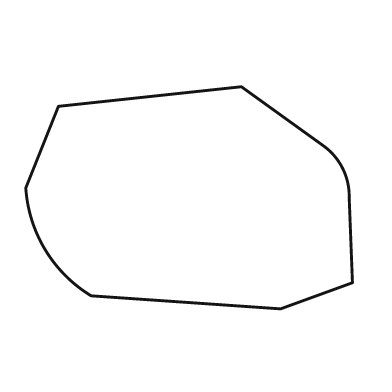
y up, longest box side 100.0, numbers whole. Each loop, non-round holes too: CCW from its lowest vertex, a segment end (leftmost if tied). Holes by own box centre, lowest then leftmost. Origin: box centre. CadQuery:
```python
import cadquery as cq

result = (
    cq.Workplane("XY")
    .moveTo(28.0, -34.0)
    .lineTo(50.0, -26.0)
    .lineTo(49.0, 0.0)
    .threePointArc((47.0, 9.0), (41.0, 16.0))
    .lineTo(16.0, 34.0)
    .lineTo(-40.0, 28.0)
    .lineTo(-50.0, 3.0)
    .threePointArc((-44.0, -16.0), (-30.0, -30.0))
    .close()
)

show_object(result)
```